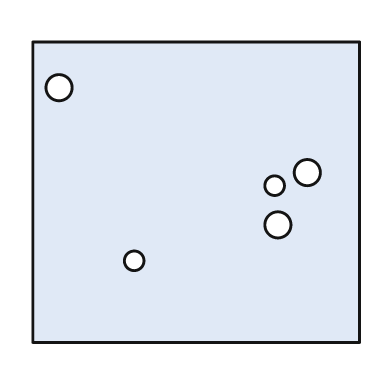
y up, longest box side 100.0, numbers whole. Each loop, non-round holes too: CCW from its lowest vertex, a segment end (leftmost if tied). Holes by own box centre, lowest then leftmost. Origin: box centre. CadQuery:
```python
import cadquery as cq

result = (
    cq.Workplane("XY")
    .moveTo(-50.0, -46.0)
    .lineTo(50.0, -46.0)
    .lineTo(50.0, 46.0)
    .lineTo(-50.0, 46.0)
    .close()
    .moveTo(-19.0, -21.0)
    .circle(3.0)
    .moveTo(25.0, -10.0)
    .circle(4.0)
    .moveTo(24.0, 2.0)
    .circle(3.0)
    .moveTo(34.0, 6.0)
    .circle(4.0)
    .moveTo(-42.0, 32.0)
    .circle(4.0)
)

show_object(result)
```